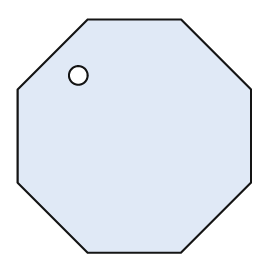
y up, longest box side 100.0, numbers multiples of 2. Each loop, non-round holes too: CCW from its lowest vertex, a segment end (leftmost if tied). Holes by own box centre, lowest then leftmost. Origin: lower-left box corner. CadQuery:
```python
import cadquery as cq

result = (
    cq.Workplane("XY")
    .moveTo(30.0, 0.0)
    .lineTo(70.0, 0.0)
    .lineTo(100.0, 30.0)
    .lineTo(100.0, 70.0)
    .lineTo(70.0, 100.0)
    .lineTo(30.0, 100.0)
    .lineTo(0.0, 70.0)
    .lineTo(0.0, 30.0)
    .close()
    .moveTo(26.0, 76.0)
    .circle(4.0)
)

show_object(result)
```